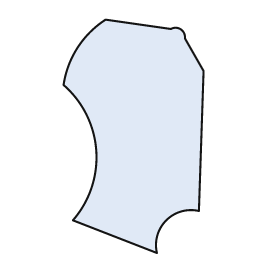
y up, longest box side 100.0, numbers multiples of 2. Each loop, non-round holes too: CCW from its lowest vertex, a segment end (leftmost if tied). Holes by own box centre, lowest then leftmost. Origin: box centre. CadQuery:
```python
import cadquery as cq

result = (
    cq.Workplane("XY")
    .moveTo(10.0, -50.0)
    .threePointArc((14.0, -36.0), (28.0, -32.0))
    .lineTo(30.0, 28.0)
    .lineTo(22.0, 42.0)
    .threePointArc((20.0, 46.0), (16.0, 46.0))
    .lineTo(-12.0, 50.0)
    .threePointArc((-24.0, 38.0), (-30.0, 22.0))
    .threePointArc((-16.0, -6.0), (-26.0, -36.0))
    .close()
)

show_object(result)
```